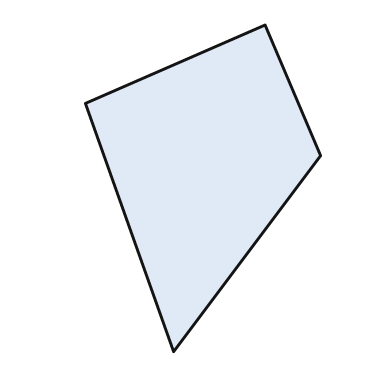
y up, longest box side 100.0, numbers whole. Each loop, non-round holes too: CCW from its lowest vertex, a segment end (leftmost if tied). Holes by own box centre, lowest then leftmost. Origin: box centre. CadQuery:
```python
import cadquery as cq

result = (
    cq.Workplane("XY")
    .moveTo(-9.0, -50.0)
    .lineTo(36.0, 10.0)
    .lineTo(19.0, 50.0)
    .lineTo(-36.0, 26.0)
    .close()
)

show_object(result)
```